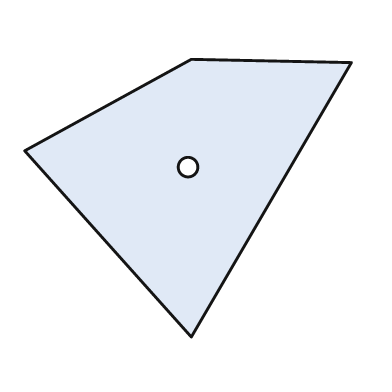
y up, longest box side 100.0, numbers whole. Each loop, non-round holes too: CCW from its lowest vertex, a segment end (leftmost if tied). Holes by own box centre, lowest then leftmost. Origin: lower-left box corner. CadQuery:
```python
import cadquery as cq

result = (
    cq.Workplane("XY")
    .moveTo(51.0, 0.0)
    .lineTo(100.0, 84.0)
    .lineTo(51.0, 85.0)
    .lineTo(0.0, 57.0)
    .close()
    .moveTo(50.0, 52.0)
    .circle(3.0)
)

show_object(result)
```